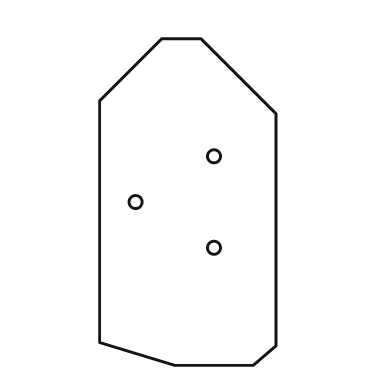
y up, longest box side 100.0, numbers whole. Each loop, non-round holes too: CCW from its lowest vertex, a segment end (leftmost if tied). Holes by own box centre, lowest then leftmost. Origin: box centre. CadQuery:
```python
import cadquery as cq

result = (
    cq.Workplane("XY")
    .moveTo(-4.0, -50.0)
    .lineTo(20.0, -50.0)
    .lineTo(27.0, -44.0)
    .lineTo(27.0, 27.0)
    .lineTo(4.0, 50.0)
    .lineTo(-8.0, 50.0)
    .lineTo(-27.0, 31.0)
    .lineTo(-27.0, -43.0)
    .close()
    .moveTo(8.0, -14.0)
    .circle(2.0)
    .moveTo(-16.0, 0.0)
    .circle(2.0)
    .moveTo(8.0, 14.0)
    .circle(2.0)
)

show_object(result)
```